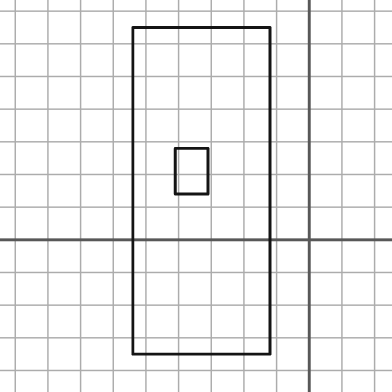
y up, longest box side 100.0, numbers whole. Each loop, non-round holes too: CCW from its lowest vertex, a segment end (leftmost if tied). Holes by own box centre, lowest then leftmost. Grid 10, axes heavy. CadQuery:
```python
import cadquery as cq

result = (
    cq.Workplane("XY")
    .moveTo(-54.0, -35.0)
    .lineTo(-12.0, -35.0)
    .lineTo(-12.0, 65.0)
    .lineTo(-54.0, 65.0)
    .close()
    .moveTo(-41.0, 14.0)
    .lineTo(-31.0, 14.0)
    .lineTo(-31.0, 28.0)
    .lineTo(-41.0, 28.0)
    .close()
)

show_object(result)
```